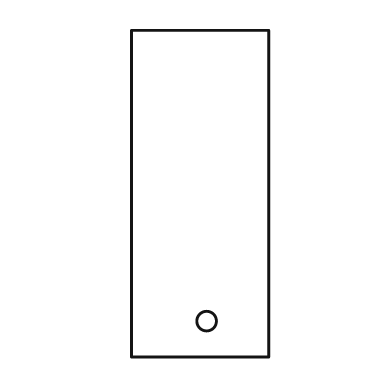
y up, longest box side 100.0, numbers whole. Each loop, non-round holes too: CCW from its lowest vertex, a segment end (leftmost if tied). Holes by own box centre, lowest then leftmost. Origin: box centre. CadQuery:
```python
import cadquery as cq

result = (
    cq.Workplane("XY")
    .moveTo(-21.0, -50.0)
    .lineTo(21.0, -50.0)
    .lineTo(21.0, 50.0)
    .lineTo(-21.0, 50.0)
    .close()
    .moveTo(2.0, -39.0)
    .circle(3.0)
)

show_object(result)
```